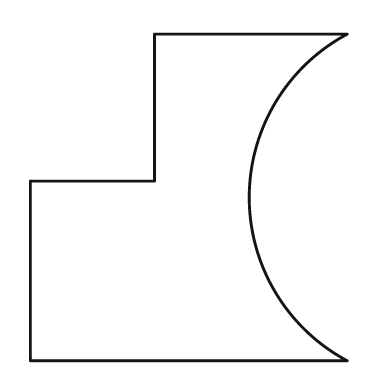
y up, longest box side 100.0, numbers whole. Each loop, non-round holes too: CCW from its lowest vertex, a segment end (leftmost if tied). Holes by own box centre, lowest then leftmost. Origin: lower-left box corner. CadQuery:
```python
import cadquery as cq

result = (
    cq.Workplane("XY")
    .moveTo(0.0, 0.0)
    .lineTo(97.0, 0.0)
    .threePointArc((67.0, 50.0), (97.0, 100.0))
    .lineTo(38.0, 100.0)
    .lineTo(38.0, 55.0)
    .lineTo(0.0, 55.0)
    .close()
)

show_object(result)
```